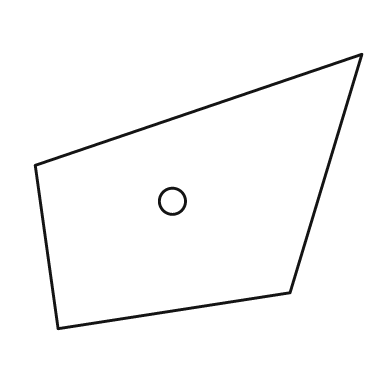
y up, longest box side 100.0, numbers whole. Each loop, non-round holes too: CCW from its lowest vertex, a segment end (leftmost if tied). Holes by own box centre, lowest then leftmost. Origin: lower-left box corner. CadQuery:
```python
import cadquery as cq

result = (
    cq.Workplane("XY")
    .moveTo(7.0, 0.0)
    .lineTo(78.0, 11.0)
    .lineTo(100.0, 84.0)
    .lineTo(0.0, 50.0)
    .close()
    .moveTo(42.0, 39.0)
    .circle(4.0)
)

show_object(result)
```